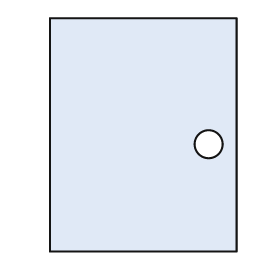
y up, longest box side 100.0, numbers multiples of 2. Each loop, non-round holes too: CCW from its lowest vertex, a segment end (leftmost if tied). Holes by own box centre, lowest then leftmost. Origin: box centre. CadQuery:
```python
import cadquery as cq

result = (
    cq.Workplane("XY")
    .moveTo(-40.0, -50.0)
    .lineTo(40.0, -50.0)
    .lineTo(40.0, 50.0)
    .lineTo(-40.0, 50.0)
    .close()
    .moveTo(28.0, -4.0)
    .circle(6.0)
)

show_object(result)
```